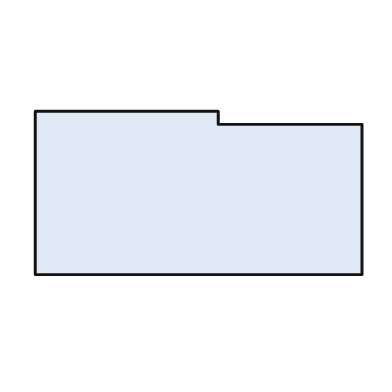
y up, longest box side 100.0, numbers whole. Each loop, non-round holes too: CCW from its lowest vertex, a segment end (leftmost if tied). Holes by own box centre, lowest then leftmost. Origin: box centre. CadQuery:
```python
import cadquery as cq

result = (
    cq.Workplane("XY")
    .moveTo(-50.0, -25.0)
    .lineTo(50.0, -25.0)
    .lineTo(50.0, 21.0)
    .lineTo(6.0, 21.0)
    .lineTo(6.0, 25.0)
    .lineTo(-50.0, 25.0)
    .close()
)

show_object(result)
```